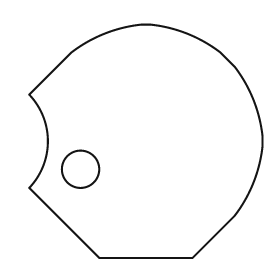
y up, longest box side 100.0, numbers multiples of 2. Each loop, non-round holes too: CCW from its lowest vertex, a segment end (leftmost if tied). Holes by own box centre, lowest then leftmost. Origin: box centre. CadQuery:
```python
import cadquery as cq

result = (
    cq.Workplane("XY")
    .moveTo(-20.0, -50.0)
    .lineTo(20.0, -50.0)
    .lineTo(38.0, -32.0)
    .threePointArc((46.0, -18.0), (50.0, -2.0))
    .lineTo(50.0, 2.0)
    .threePointArc((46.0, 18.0), (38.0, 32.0))
    .lineTo(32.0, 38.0)
    .threePointArc((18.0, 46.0), (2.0, 50.0))
    .lineTo(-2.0, 50.0)
    .threePointArc((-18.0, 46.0), (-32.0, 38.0))
    .lineTo(-50.0, 20.0)
    .threePointArc((-42.0, 0.0), (-50.0, -20.0))
    .close()
    .moveTo(-28.0, -12.0)
    .circle(8.0)
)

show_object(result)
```